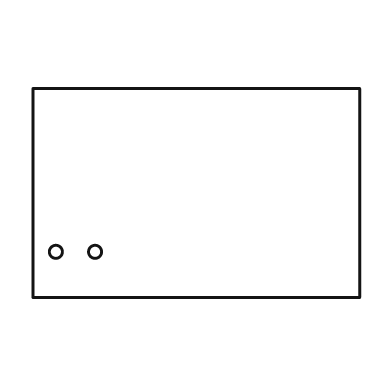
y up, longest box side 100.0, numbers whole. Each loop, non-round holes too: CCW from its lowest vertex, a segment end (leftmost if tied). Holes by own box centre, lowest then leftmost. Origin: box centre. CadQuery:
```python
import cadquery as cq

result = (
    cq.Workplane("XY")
    .moveTo(-50.0, -32.0)
    .lineTo(50.0, -32.0)
    .lineTo(50.0, 32.0)
    .lineTo(-50.0, 32.0)
    .close()
    .moveTo(-43.0, -18.0)
    .circle(2.0)
    .moveTo(-31.0, -18.0)
    .circle(2.0)
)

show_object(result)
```